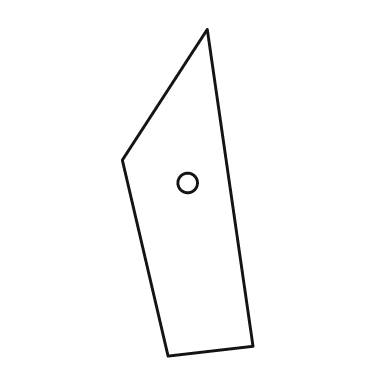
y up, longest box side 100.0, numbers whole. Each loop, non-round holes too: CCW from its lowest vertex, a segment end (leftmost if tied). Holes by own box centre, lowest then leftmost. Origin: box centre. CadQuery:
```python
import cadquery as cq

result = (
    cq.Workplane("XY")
    .moveTo(-6.0, -50.0)
    .lineTo(20.0, -47.0)
    .lineTo(6.0, 50.0)
    .lineTo(-20.0, 10.0)
    .close()
    .moveTo(0.0, 3.0)
    .circle(3.0)
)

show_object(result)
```